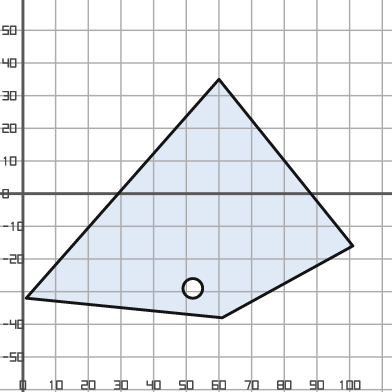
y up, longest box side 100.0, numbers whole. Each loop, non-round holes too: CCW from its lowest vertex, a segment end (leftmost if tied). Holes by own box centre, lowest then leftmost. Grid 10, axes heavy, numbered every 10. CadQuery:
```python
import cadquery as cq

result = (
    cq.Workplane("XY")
    .moveTo(61.0, -38.0)
    .lineTo(101.0, -16.0)
    .lineTo(60.0, 35.0)
    .lineTo(1.0, -32.0)
    .close()
    .moveTo(52.0, -29.0)
    .circle(3.0)
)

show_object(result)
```